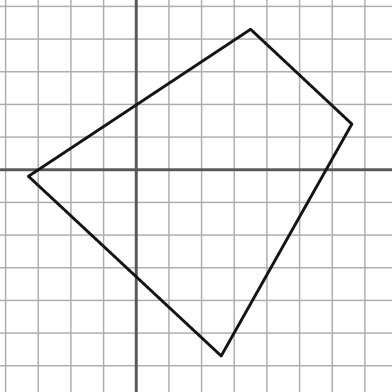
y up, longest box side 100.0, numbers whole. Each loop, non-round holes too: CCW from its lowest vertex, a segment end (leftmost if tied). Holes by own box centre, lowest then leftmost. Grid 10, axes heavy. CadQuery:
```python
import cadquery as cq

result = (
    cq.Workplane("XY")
    .moveTo(26.0, -57.0)
    .lineTo(66.0, 14.0)
    .lineTo(35.0, 43.0)
    .lineTo(-33.0, -2.0)
    .close()
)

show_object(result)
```